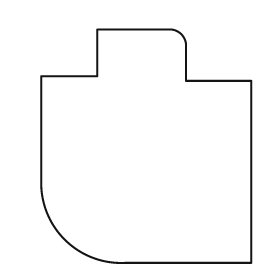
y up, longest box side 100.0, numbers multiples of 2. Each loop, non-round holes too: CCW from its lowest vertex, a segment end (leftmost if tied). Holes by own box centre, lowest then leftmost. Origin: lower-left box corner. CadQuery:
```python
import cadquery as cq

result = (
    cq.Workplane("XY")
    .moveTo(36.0, 0.0)
    .lineTo(90.0, 0.0)
    .lineTo(90.0, 78.0)
    .lineTo(62.0, 78.0)
    .lineTo(62.0, 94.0)
    .threePointArc((60.0, 98.0), (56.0, 100.0))
    .lineTo(24.0, 100.0)
    .lineTo(24.0, 80.0)
    .lineTo(0.0, 80.0)
    .lineTo(0.0, 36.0)
    .threePointArc((10.0, 10.0), (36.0, 0.0))
    .close()
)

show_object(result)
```